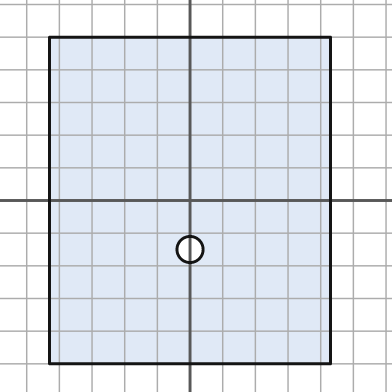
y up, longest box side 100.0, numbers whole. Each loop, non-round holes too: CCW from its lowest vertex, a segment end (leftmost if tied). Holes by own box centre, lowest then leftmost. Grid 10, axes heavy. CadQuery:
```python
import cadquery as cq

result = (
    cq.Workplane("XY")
    .moveTo(-43.0, -50.0)
    .lineTo(43.0, -50.0)
    .lineTo(43.0, 50.0)
    .lineTo(-43.0, 50.0)
    .close()
    .moveTo(0.0, -15.0)
    .circle(4.0)
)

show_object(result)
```